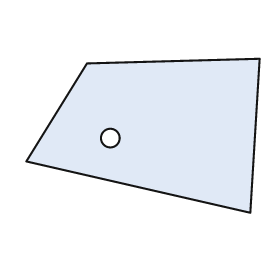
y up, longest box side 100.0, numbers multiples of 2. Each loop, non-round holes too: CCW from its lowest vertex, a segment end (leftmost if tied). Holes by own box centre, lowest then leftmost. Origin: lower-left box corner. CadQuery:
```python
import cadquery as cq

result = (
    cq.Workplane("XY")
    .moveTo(96.0, 0.0)
    .lineTo(100.0, 66.0)
    .lineTo(26.0, 64.0)
    .lineTo(0.0, 22.0)
    .close()
    .moveTo(36.0, 32.0)
    .circle(4.0)
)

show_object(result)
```